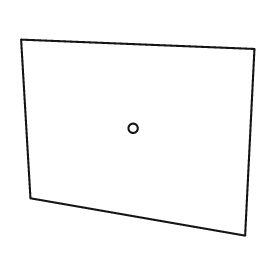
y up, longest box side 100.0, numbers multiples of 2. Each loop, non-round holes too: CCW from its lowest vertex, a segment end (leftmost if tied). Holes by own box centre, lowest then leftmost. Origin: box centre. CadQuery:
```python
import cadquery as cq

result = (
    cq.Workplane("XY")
    .moveTo(46.0, -42.0)
    .lineTo(50.0, 38.0)
    .lineTo(-50.0, 42.0)
    .lineTo(-46.0, -26.0)
    .close()
    .moveTo(-2.0, 4.0)
    .circle(2.0)
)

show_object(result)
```